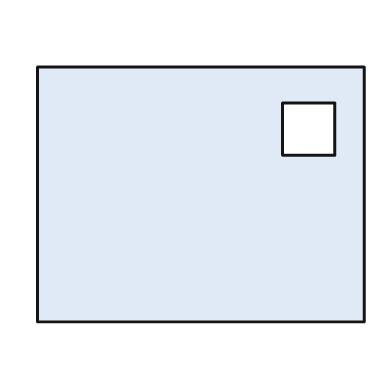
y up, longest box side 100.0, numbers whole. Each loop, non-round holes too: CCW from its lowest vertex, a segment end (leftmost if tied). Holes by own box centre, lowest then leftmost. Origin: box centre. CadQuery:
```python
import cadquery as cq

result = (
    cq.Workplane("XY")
    .moveTo(-50.0, -39.0)
    .lineTo(50.0, -39.0)
    .lineTo(50.0, 39.0)
    .lineTo(-50.0, 39.0)
    .close()
    .moveTo(25.0, 12.0)
    .lineTo(41.0, 12.0)
    .lineTo(41.0, 28.0)
    .lineTo(25.0, 28.0)
    .close()
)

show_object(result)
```